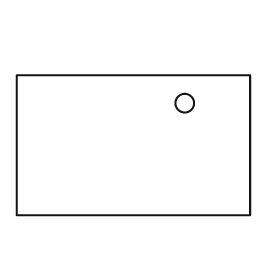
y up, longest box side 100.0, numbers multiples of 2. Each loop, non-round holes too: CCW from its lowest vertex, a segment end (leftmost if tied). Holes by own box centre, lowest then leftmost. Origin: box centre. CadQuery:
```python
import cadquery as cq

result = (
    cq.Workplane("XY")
    .moveTo(-50.0, -30.0)
    .lineTo(50.0, -30.0)
    .lineTo(50.0, 30.0)
    .lineTo(-50.0, 30.0)
    .close()
    .moveTo(22.0, 18.0)
    .circle(4.0)
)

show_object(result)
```